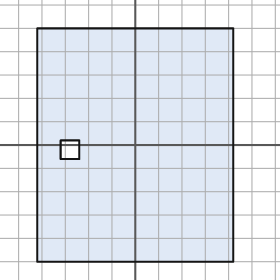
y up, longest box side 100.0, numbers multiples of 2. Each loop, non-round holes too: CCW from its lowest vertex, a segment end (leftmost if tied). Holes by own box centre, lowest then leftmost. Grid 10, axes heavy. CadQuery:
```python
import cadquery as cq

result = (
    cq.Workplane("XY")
    .moveTo(-42.0, -50.0)
    .lineTo(42.0, -50.0)
    .lineTo(42.0, 50.0)
    .lineTo(-42.0, 50.0)
    .close()
    .moveTo(-32.0, -6.0)
    .lineTo(-24.0, -6.0)
    .lineTo(-24.0, 2.0)
    .lineTo(-32.0, 2.0)
    .close()
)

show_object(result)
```